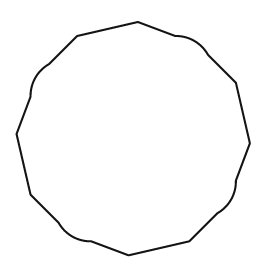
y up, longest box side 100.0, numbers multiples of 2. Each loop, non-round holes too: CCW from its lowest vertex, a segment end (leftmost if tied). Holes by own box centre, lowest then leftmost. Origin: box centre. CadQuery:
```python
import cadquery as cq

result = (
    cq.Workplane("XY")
    .moveTo(-2.0, -50.0)
    .lineTo(24.0, -44.0)
    .lineTo(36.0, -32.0)
    .threePointArc((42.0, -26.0), (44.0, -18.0))
    .lineTo(50.0, -2.0)
    .lineTo(44.0, 24.0)
    .lineTo(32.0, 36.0)
    .threePointArc((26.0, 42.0), (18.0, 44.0))
    .lineTo(2.0, 50.0)
    .lineTo(-24.0, 44.0)
    .lineTo(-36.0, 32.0)
    .threePointArc((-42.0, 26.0), (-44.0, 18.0))
    .lineTo(-50.0, 2.0)
    .lineTo(-44.0, -24.0)
    .lineTo(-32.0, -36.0)
    .threePointArc((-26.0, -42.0), (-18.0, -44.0))
    .close()
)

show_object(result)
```